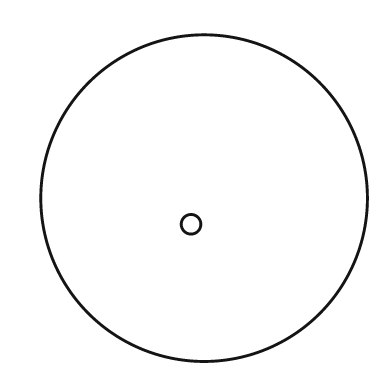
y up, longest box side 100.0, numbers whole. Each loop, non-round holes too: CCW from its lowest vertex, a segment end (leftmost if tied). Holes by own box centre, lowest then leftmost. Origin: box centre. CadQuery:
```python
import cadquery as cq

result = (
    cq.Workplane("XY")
    .moveTo(0.0, 0.0)
    .circle(50.0)
    .moveTo(-4.0, -8.0)
    .circle(3.0)
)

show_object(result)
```